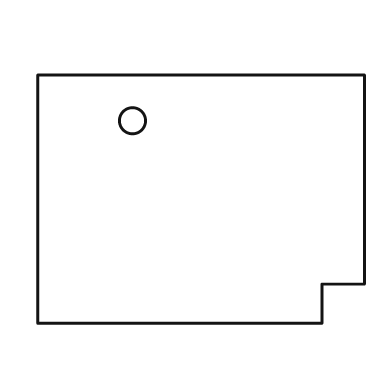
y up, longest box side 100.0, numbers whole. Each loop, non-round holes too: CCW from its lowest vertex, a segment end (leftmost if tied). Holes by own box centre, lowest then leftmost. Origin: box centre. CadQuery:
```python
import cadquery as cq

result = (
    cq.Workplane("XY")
    .moveTo(-50.0, -38.0)
    .lineTo(37.0, -38.0)
    .lineTo(37.0, -26.0)
    .lineTo(50.0, -26.0)
    .lineTo(50.0, 38.0)
    .lineTo(-50.0, 38.0)
    .close()
    .moveTo(-21.0, 24.0)
    .circle(4.0)
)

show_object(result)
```